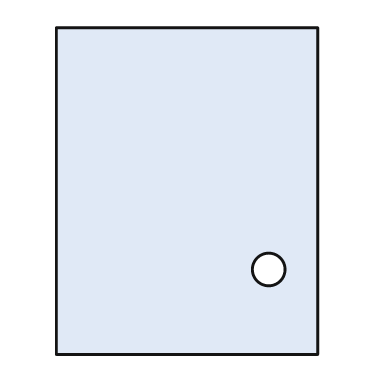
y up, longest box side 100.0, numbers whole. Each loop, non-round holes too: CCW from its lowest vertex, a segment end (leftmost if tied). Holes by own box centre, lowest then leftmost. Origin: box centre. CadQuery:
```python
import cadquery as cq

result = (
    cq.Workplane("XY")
    .moveTo(-40.0, -50.0)
    .lineTo(40.0, -50.0)
    .lineTo(40.0, 50.0)
    .lineTo(-40.0, 50.0)
    .close()
    .moveTo(25.0, -24.0)
    .circle(5.0)
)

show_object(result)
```